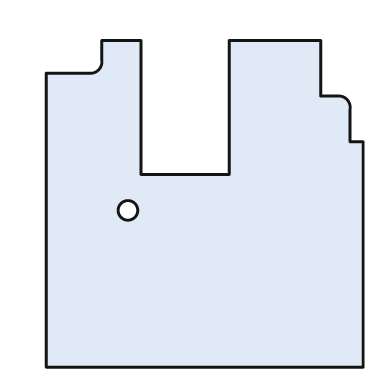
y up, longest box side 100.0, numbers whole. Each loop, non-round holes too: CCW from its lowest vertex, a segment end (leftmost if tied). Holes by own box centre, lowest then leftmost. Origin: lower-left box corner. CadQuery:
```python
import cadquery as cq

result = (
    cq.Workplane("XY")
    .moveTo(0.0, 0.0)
    .lineTo(97.0, 0.0)
    .lineTo(97.0, 69.0)
    .lineTo(93.0, 69.0)
    .lineTo(93.0, 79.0)
    .threePointArc((92.0, 82.0), (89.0, 83.0))
    .lineTo(84.0, 83.0)
    .lineTo(84.0, 100.0)
    .lineTo(56.0, 100.0)
    .lineTo(56.0, 59.0)
    .lineTo(29.0, 59.0)
    .lineTo(29.0, 100.0)
    .lineTo(17.0, 100.0)
    .lineTo(17.0, 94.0)
    .threePointArc((16.0, 91.0), (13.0, 90.0))
    .lineTo(0.0, 90.0)
    .close()
    .moveTo(25.0, 48.0)
    .circle(3.0)
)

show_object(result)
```